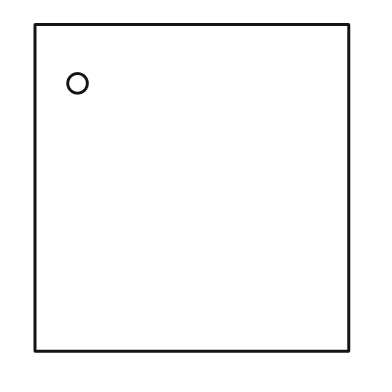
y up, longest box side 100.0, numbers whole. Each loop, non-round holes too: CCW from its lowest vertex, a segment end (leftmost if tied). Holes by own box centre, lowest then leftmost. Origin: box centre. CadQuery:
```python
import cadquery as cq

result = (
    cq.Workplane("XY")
    .moveTo(-48.0, -50.0)
    .lineTo(48.0, -50.0)
    .lineTo(48.0, 50.0)
    .lineTo(-48.0, 50.0)
    .close()
    .moveTo(-35.0, 32.0)
    .circle(3.0)
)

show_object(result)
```